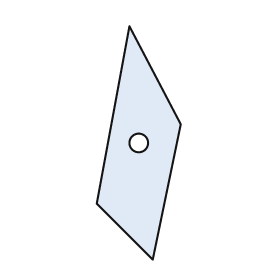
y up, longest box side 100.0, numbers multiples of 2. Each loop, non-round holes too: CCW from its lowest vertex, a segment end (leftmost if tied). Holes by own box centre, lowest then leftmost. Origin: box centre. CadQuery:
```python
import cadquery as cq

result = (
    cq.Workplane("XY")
    .moveTo(6.0, -50.0)
    .lineTo(18.0, 8.0)
    .lineTo(-4.0, 50.0)
    .lineTo(-18.0, -26.0)
    .close()
    .moveTo(0.0, 0.0)
    .circle(4.0)
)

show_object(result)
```